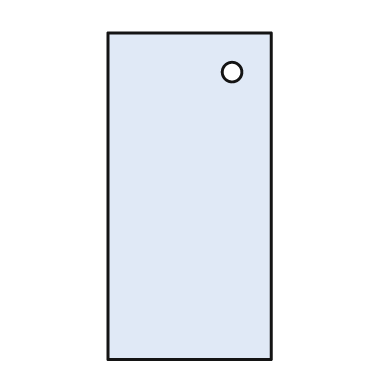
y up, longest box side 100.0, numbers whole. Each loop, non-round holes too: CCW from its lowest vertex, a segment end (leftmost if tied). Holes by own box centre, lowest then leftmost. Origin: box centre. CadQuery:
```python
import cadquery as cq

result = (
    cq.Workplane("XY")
    .moveTo(-25.0, -50.0)
    .lineTo(25.0, -50.0)
    .lineTo(25.0, 50.0)
    .lineTo(-25.0, 50.0)
    .close()
    .moveTo(13.0, 38.0)
    .circle(3.0)
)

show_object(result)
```